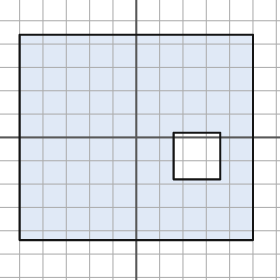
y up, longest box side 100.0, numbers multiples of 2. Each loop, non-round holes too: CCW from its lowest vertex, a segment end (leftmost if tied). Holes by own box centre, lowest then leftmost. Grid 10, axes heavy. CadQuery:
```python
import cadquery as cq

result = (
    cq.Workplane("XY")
    .moveTo(-50.0, -44.0)
    .lineTo(50.0, -44.0)
    .lineTo(50.0, 44.0)
    .lineTo(-50.0, 44.0)
    .close()
    .moveTo(16.0, -18.0)
    .lineTo(36.0, -18.0)
    .lineTo(36.0, 2.0)
    .lineTo(16.0, 2.0)
    .close()
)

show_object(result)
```